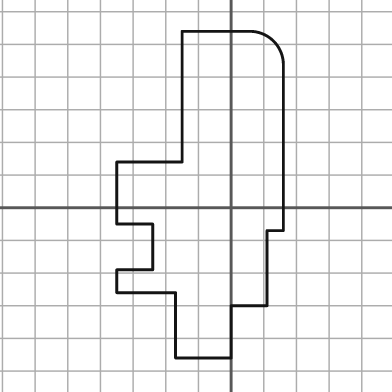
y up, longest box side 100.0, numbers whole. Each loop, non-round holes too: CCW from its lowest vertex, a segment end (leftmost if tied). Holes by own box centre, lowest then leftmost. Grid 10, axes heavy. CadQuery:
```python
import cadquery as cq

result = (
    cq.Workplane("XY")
    .moveTo(-17.0, -46.0)
    .lineTo(0.0, -46.0)
    .lineTo(0.0, -30.0)
    .lineTo(11.0, -30.0)
    .lineTo(11.0, -7.0)
    .lineTo(16.0, -7.0)
    .lineTo(16.0, 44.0)
    .threePointArc((13.0, 51.0), (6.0, 54.0))
    .lineTo(-15.0, 54.0)
    .lineTo(-15.0, 14.0)
    .lineTo(-35.0, 14.0)
    .lineTo(-35.0, -5.0)
    .lineTo(-24.0, -5.0)
    .lineTo(-24.0, -19.0)
    .lineTo(-35.0, -19.0)
    .lineTo(-35.0, -26.0)
    .lineTo(-17.0, -26.0)
    .close()
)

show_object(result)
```